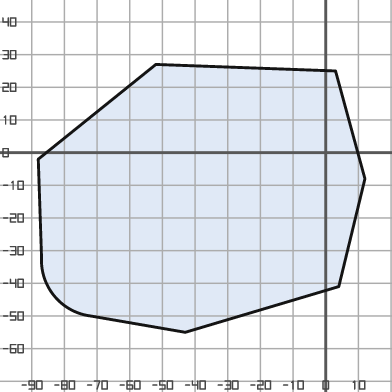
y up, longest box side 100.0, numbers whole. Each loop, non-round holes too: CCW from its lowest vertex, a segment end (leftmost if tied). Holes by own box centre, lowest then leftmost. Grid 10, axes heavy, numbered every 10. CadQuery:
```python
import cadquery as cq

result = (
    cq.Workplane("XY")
    .moveTo(-43.0, -55.0)
    .lineTo(4.0, -41.0)
    .lineTo(12.0, -8.0)
    .lineTo(3.0, 25.0)
    .lineTo(-52.0, 27.0)
    .lineTo(-88.0, -2.0)
    .lineTo(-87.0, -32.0)
    .threePointArc((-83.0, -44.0), (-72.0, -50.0))
    .close()
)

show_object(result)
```